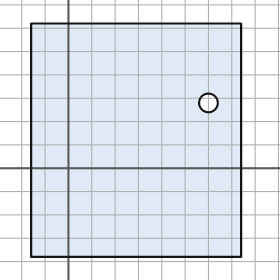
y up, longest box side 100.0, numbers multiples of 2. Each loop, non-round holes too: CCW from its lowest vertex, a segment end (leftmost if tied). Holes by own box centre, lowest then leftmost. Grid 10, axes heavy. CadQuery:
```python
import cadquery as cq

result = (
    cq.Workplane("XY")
    .moveTo(-16.0, -38.0)
    .lineTo(74.0, -38.0)
    .lineTo(74.0, 62.0)
    .lineTo(-16.0, 62.0)
    .close()
    .moveTo(60.0, 28.0)
    .circle(4.0)
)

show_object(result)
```